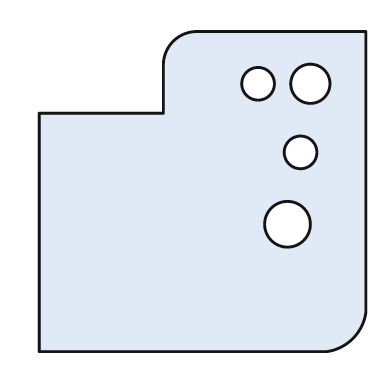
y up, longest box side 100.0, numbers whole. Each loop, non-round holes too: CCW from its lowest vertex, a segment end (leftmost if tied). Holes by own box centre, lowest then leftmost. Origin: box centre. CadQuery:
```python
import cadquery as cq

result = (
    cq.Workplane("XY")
    .moveTo(-50.0, -49.0)
    .lineTo(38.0, -49.0)
    .threePointArc((46.0, -45.0), (50.0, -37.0))
    .lineTo(50.0, 49.0)
    .lineTo(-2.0, 49.0)
    .threePointArc((-9.0, 46.0), (-12.0, 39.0))
    .lineTo(-12.0, 24.0)
    .lineTo(-50.0, 24.0)
    .close()
    .moveTo(26.0, -10.0)
    .circle(7.0)
    .moveTo(30.0, 12.0)
    .circle(5.0)
    .moveTo(17.0, 33.0)
    .circle(5.0)
    .moveTo(33.0, 33.0)
    .circle(6.0)
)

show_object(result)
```